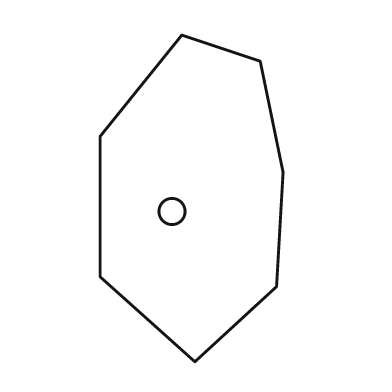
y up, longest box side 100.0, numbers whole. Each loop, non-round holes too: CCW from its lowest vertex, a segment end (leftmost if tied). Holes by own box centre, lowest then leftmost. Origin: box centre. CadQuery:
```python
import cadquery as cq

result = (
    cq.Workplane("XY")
    .moveTo(1.0, -50.0)
    .lineTo(26.0, -27.0)
    .lineTo(28.0, 8.0)
    .lineTo(21.0, 42.0)
    .lineTo(-3.0, 50.0)
    .lineTo(-28.0, 19.0)
    .lineTo(-28.0, -24.0)
    .close()
    .moveTo(-6.0, -4.0)
    .circle(4.0)
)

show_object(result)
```